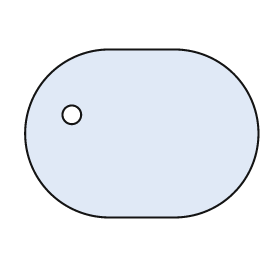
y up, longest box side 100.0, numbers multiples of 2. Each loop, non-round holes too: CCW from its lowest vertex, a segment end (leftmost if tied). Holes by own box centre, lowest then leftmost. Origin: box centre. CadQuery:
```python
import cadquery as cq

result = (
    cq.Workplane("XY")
    .moveTo(-14.0, -36.0)
    .lineTo(14.0, -36.0)
    .threePointArc((50.0, 0.0), (14.0, 36.0))
    .lineTo(-14.0, 36.0)
    .threePointArc((-50.0, 0.0), (-14.0, -36.0))
    .close()
    .moveTo(-30.0, 8.0)
    .circle(4.0)
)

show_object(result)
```